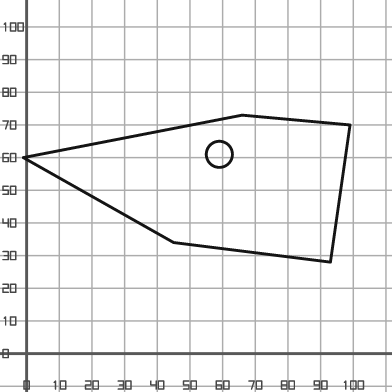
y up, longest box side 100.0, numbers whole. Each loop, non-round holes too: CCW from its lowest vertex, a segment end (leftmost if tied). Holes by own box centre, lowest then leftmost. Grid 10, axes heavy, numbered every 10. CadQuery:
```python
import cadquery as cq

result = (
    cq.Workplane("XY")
    .moveTo(93.0, 28.0)
    .lineTo(99.0, 70.0)
    .lineTo(66.0, 73.0)
    .lineTo(-1.0, 60.0)
    .lineTo(45.0, 34.0)
    .close()
    .moveTo(59.0, 61.0)
    .circle(4.0)
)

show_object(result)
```